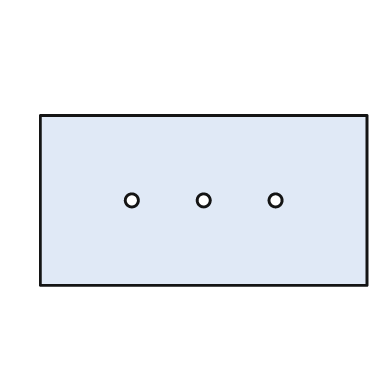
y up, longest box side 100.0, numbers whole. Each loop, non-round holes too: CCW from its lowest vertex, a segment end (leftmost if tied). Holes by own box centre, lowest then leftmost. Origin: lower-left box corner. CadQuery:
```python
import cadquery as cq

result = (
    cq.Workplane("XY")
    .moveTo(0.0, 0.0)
    .lineTo(100.0, 0.0)
    .lineTo(100.0, 52.0)
    .lineTo(0.0, 52.0)
    .close()
    .moveTo(28.0, 26.0)
    .circle(2.0)
    .moveTo(50.0, 26.0)
    .circle(2.0)
    .moveTo(72.0, 26.0)
    .circle(2.0)
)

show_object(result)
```